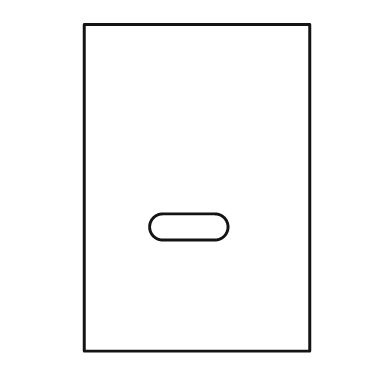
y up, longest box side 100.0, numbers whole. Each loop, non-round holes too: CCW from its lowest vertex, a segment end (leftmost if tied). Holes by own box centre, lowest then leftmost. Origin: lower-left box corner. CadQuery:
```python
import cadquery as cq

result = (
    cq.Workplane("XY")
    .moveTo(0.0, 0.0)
    .lineTo(69.0, 0.0)
    .lineTo(69.0, 100.0)
    .lineTo(0.0, 100.0)
    .close()
    .moveTo(24.0, 34.0)
    .lineTo(40.0, 34.0)
    .threePointArc((44.0, 38.0), (40.0, 42.0))
    .lineTo(24.0, 42.0)
    .threePointArc((20.0, 38.0), (24.0, 34.0))
    .close()
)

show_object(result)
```